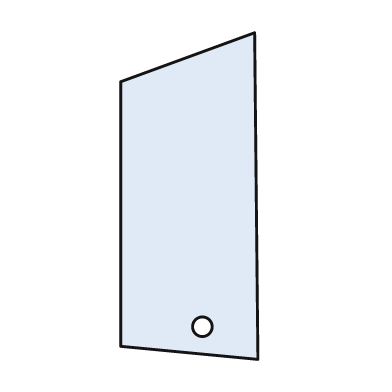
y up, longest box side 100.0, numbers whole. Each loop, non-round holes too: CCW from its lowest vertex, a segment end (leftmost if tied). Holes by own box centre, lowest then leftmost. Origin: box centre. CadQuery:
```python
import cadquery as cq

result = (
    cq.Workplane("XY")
    .moveTo(21.0, -50.0)
    .lineTo(20.0, 50.0)
    .lineTo(-21.0, 35.0)
    .lineTo(-21.0, -46.0)
    .close()
    .moveTo(4.0, -40.0)
    .circle(3.0)
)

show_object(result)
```